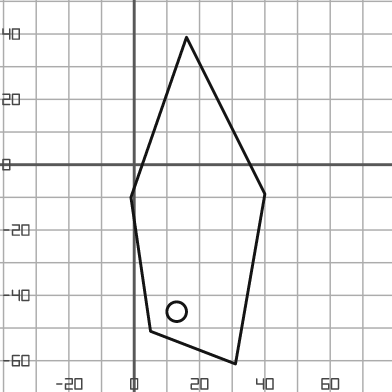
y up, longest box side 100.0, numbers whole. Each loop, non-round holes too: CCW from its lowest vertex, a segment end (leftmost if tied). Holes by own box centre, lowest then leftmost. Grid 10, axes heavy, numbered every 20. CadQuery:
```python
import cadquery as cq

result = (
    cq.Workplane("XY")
    .moveTo(31.0, -61.0)
    .lineTo(40.0, -9.0)
    .lineTo(16.0, 39.0)
    .lineTo(-1.0, -10.0)
    .lineTo(5.0, -51.0)
    .close()
    .moveTo(13.0, -45.0)
    .circle(3.0)
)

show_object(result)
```